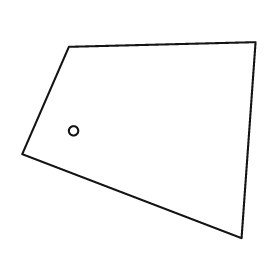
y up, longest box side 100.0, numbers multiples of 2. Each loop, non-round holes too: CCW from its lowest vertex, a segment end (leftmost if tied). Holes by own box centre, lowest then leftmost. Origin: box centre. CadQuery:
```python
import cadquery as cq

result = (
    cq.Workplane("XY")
    .moveTo(44.0, -42.0)
    .lineTo(50.0, 42.0)
    .lineTo(-30.0, 40.0)
    .lineTo(-50.0, -6.0)
    .close()
    .moveTo(-28.0, 4.0)
    .circle(2.0)
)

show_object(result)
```